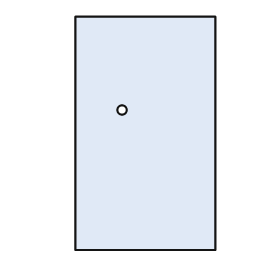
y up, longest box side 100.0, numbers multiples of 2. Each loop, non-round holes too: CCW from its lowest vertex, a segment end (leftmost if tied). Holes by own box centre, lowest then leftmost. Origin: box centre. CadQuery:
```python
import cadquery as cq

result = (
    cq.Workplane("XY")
    .moveTo(-30.0, -50.0)
    .lineTo(30.0, -50.0)
    .lineTo(30.0, 50.0)
    .lineTo(-30.0, 50.0)
    .close()
    .moveTo(-10.0, 10.0)
    .circle(2.0)
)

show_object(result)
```